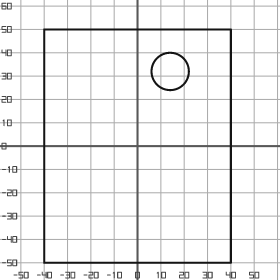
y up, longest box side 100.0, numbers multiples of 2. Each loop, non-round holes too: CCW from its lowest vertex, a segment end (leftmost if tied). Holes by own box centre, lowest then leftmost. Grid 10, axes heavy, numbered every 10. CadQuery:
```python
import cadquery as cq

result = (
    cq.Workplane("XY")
    .moveTo(-40.0, -50.0)
    .lineTo(40.0, -50.0)
    .lineTo(40.0, 50.0)
    .lineTo(-40.0, 50.0)
    .close()
    .moveTo(14.0, 32.0)
    .circle(8.0)
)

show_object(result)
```